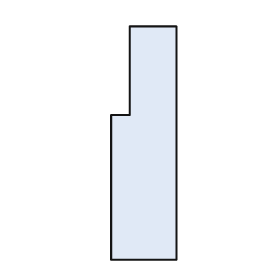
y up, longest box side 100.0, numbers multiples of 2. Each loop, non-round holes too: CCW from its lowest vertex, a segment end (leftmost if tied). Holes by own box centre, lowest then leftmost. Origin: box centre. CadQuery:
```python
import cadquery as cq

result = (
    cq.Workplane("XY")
    .moveTo(-14.0, -50.0)
    .lineTo(14.0, -50.0)
    .lineTo(14.0, 50.0)
    .lineTo(-6.0, 50.0)
    .lineTo(-6.0, 12.0)
    .lineTo(-14.0, 12.0)
    .close()
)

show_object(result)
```